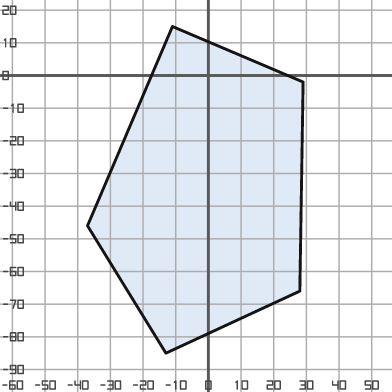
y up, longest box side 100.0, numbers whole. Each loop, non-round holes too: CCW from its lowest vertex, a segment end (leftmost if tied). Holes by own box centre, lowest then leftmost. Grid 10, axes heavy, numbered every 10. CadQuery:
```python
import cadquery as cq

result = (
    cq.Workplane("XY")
    .moveTo(-13.0, -85.0)
    .lineTo(28.0, -66.0)
    .lineTo(29.0, -2.0)
    .lineTo(-11.0, 15.0)
    .lineTo(-37.0, -46.0)
    .close()
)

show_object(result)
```